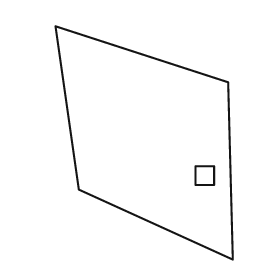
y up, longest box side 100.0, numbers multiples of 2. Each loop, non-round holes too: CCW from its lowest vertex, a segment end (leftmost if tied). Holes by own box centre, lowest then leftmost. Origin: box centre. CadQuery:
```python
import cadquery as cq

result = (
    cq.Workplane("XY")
    .moveTo(38.0, -50.0)
    .lineTo(36.0, 26.0)
    .lineTo(-38.0, 50.0)
    .lineTo(-28.0, -20.0)
    .close()
    .moveTo(22.0, -18.0)
    .lineTo(30.0, -18.0)
    .lineTo(30.0, -10.0)
    .lineTo(22.0, -10.0)
    .close()
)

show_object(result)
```